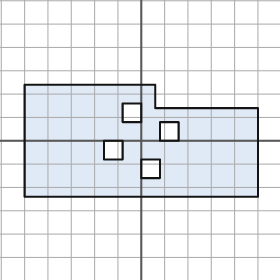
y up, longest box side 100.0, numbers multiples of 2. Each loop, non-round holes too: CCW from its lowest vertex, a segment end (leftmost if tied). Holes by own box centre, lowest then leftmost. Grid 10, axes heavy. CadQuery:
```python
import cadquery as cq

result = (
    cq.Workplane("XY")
    .moveTo(-50.0, -24.0)
    .lineTo(50.0, -24.0)
    .lineTo(50.0, 14.0)
    .lineTo(6.0, 14.0)
    .lineTo(6.0, 24.0)
    .lineTo(-50.0, 24.0)
    .close()
    .moveTo(0.0, -16.0)
    .lineTo(8.0, -16.0)
    .lineTo(8.0, -8.0)
    .lineTo(0.0, -8.0)
    .close()
    .moveTo(-16.0, -8.0)
    .lineTo(-8.0, -8.0)
    .lineTo(-8.0, 0.0)
    .lineTo(-16.0, 0.0)
    .close()
    .moveTo(8.0, 0.0)
    .lineTo(16.0, 0.0)
    .lineTo(16.0, 8.0)
    .lineTo(8.0, 8.0)
    .close()
    .moveTo(-8.0, 8.0)
    .lineTo(0.0, 8.0)
    .lineTo(0.0, 16.0)
    .lineTo(-8.0, 16.0)
    .close()
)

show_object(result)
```